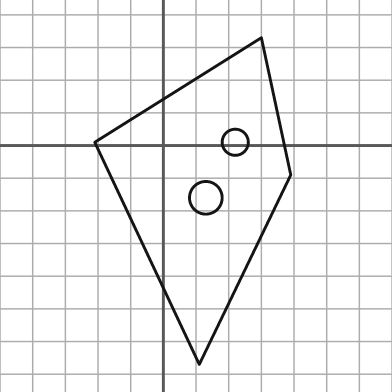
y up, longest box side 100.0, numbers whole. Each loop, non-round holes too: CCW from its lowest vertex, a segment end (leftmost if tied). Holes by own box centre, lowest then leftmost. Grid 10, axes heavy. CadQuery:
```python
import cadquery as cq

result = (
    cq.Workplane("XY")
    .moveTo(11.0, -67.0)
    .lineTo(39.0, -9.0)
    .lineTo(30.0, 33.0)
    .lineTo(-21.0, 1.0)
    .close()
    .moveTo(13.0, -16.0)
    .circle(5.0)
    .moveTo(22.0, 1.0)
    .circle(4.0)
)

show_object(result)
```